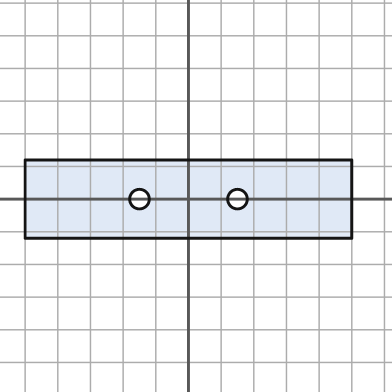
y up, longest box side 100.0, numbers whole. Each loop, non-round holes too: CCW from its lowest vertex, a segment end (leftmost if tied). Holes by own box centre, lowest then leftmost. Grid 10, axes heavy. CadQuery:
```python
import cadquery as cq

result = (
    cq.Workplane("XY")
    .moveTo(-50.0, -12.0)
    .lineTo(50.0, -12.0)
    .lineTo(50.0, 12.0)
    .lineTo(-50.0, 12.0)
    .close()
    .moveTo(-15.0, 0.0)
    .circle(3.0)
    .moveTo(15.0, 0.0)
    .circle(3.0)
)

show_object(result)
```